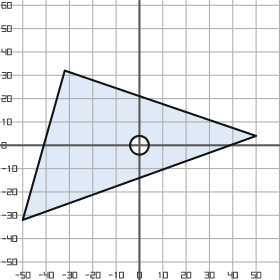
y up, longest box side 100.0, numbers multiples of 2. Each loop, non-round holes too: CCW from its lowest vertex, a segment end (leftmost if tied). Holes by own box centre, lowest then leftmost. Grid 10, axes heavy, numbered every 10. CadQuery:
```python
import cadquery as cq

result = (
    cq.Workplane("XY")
    .moveTo(-50.0, -32.0)
    .lineTo(50.0, 4.0)
    .lineTo(-32.0, 32.0)
    .close()
    .moveTo(0.0, 0.0)
    .circle(4.0)
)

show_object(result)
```